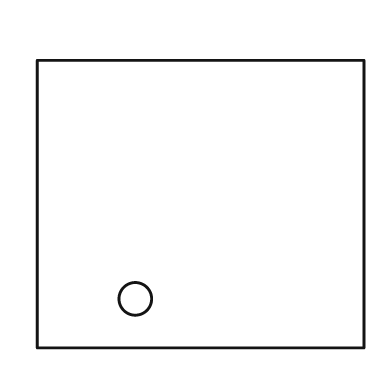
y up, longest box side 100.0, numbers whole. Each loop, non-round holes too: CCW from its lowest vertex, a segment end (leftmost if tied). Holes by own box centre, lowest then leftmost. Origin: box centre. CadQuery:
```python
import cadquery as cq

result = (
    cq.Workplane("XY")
    .moveTo(-50.0, -44.0)
    .lineTo(50.0, -44.0)
    .lineTo(50.0, 44.0)
    .lineTo(-50.0, 44.0)
    .close()
    .moveTo(-20.0, -29.0)
    .circle(5.0)
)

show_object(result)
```